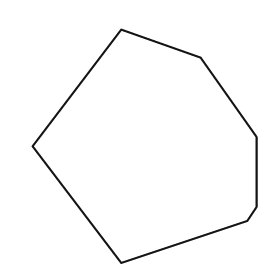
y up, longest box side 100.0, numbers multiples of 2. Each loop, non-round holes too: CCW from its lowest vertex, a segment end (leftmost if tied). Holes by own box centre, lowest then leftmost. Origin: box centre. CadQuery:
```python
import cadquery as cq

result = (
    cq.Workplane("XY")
    .moveTo(-10.0, -50.0)
    .lineTo(44.0, -32.0)
    .lineTo(48.0, -26.0)
    .lineTo(48.0, 4.0)
    .lineTo(24.0, 38.0)
    .lineTo(-10.0, 50.0)
    .lineTo(-48.0, 0.0)
    .close()
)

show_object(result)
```